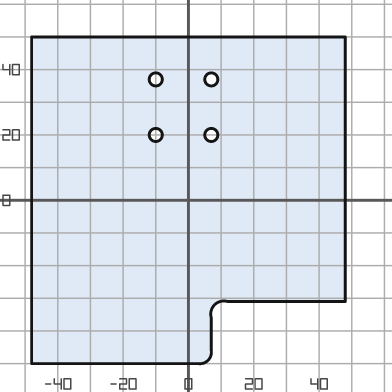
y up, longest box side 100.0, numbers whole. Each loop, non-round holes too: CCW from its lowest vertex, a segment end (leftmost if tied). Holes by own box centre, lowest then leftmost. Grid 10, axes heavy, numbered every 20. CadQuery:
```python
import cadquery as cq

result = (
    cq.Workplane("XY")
    .moveTo(-48.0, -50.0)
    .lineTo(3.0, -50.0)
    .threePointArc((6.0, -49.0), (7.0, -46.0))
    .lineTo(7.0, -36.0)
    .threePointArc((8.0, -32.0), (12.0, -31.0))
    .lineTo(48.0, -31.0)
    .lineTo(48.0, 50.0)
    .lineTo(-48.0, 50.0)
    .close()
    .moveTo(-10.0, 20.0)
    .circle(2.0)
    .moveTo(7.0, 20.0)
    .circle(2.0)
    .moveTo(-10.0, 37.0)
    .circle(2.0)
    .moveTo(7.0, 37.0)
    .circle(2.0)
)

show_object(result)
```